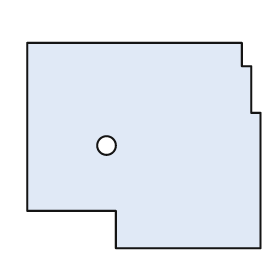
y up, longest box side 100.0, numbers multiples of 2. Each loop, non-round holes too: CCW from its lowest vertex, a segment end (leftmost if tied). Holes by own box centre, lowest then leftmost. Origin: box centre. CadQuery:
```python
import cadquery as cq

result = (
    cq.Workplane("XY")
    .moveTo(-12.0, -44.0)
    .lineTo(50.0, -44.0)
    .lineTo(50.0, 14.0)
    .lineTo(46.0, 14.0)
    .lineTo(46.0, 34.0)
    .lineTo(42.0, 34.0)
    .lineTo(42.0, 44.0)
    .lineTo(-50.0, 44.0)
    .lineTo(-50.0, -28.0)
    .lineTo(-12.0, -28.0)
    .close()
    .moveTo(-16.0, 0.0)
    .circle(4.0)
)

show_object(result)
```